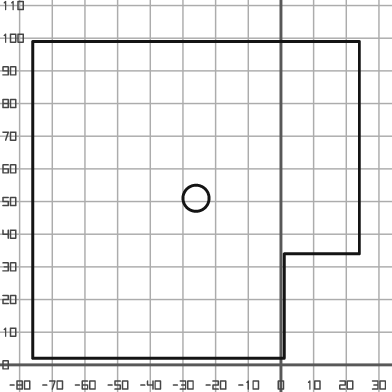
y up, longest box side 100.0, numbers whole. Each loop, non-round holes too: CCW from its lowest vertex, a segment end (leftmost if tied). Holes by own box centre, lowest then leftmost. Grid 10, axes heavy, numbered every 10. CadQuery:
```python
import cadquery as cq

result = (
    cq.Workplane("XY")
    .moveTo(-76.0, 2.0)
    .lineTo(1.0, 2.0)
    .lineTo(1.0, 34.0)
    .lineTo(24.0, 34.0)
    .lineTo(24.0, 99.0)
    .lineTo(-76.0, 99.0)
    .close()
    .moveTo(-26.0, 51.0)
    .circle(4.0)
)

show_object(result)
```